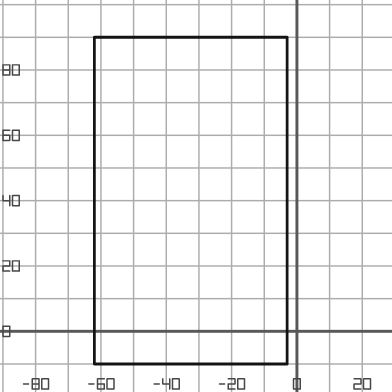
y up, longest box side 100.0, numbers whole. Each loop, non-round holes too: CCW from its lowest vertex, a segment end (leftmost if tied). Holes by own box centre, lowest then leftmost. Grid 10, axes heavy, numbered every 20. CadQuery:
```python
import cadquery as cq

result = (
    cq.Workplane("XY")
    .moveTo(-62.0, -10.0)
    .lineTo(-3.0, -10.0)
    .lineTo(-3.0, 90.0)
    .lineTo(-62.0, 90.0)
    .close()
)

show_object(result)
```